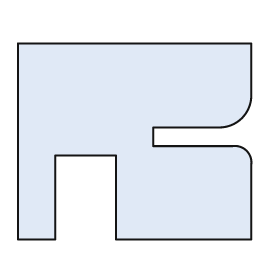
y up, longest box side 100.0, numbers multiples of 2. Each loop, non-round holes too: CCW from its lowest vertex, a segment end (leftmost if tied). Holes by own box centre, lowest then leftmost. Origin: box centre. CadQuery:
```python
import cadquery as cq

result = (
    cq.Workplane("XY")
    .moveTo(-50.0, -42.0)
    .lineTo(-34.0, -42.0)
    .lineTo(-34.0, -6.0)
    .lineTo(-8.0, -6.0)
    .lineTo(-8.0, -42.0)
    .lineTo(50.0, -42.0)
    .lineTo(50.0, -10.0)
    .threePointArc((48.0, -4.0), (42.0, -2.0))
    .lineTo(8.0, -2.0)
    .lineTo(8.0, 6.0)
    .lineTo(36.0, 6.0)
    .threePointArc((46.0, 10.0), (50.0, 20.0))
    .lineTo(50.0, 42.0)
    .lineTo(-50.0, 42.0)
    .close()
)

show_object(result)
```